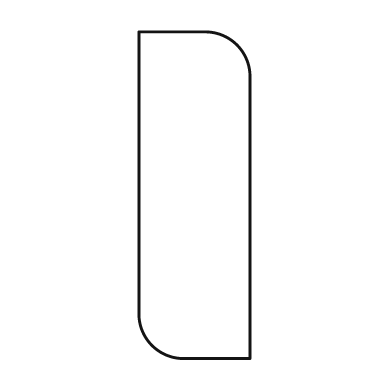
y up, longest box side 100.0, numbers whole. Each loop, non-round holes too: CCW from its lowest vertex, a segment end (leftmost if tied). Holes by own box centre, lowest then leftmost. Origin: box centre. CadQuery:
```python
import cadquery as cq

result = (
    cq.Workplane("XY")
    .moveTo(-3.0, -50.0)
    .lineTo(17.0, -50.0)
    .lineTo(17.0, 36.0)
    .threePointArc((13.0, 46.0), (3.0, 50.0))
    .lineTo(-17.0, 50.0)
    .lineTo(-17.0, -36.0)
    .threePointArc((-13.0, -46.0), (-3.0, -50.0))
    .close()
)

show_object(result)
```